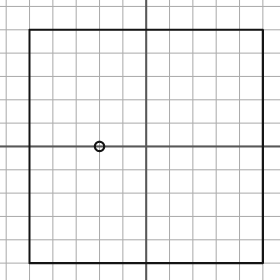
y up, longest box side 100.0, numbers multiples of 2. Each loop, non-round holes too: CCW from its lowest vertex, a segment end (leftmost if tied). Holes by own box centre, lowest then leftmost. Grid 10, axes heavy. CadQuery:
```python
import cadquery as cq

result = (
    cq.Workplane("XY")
    .moveTo(-50.0, -50.0)
    .lineTo(50.0, -50.0)
    .lineTo(50.0, 50.0)
    .lineTo(-50.0, 50.0)
    .close()
    .moveTo(-20.0, 0.0)
    .circle(2.0)
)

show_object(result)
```